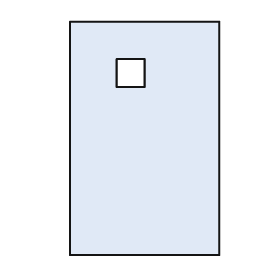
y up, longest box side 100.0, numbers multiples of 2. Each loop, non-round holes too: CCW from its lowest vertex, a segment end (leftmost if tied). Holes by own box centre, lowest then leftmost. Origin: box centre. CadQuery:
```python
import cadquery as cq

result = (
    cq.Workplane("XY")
    .moveTo(-32.0, -50.0)
    .lineTo(32.0, -50.0)
    .lineTo(32.0, 50.0)
    .lineTo(-32.0, 50.0)
    .close()
    .moveTo(-12.0, 22.0)
    .lineTo(0.0, 22.0)
    .lineTo(0.0, 34.0)
    .lineTo(-12.0, 34.0)
    .close()
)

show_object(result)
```